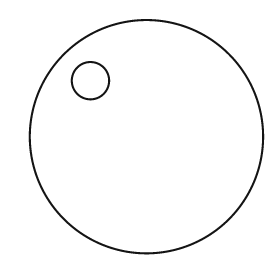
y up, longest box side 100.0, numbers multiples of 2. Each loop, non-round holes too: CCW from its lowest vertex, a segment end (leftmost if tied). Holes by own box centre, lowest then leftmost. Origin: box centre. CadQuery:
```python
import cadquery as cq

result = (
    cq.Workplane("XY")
    .moveTo(0.0, 0.0)
    .circle(50.0)
    .moveTo(-24.0, 24.0)
    .circle(8.0)
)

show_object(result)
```